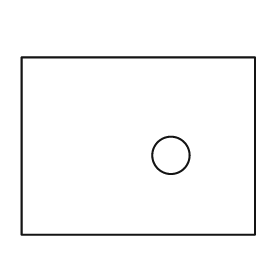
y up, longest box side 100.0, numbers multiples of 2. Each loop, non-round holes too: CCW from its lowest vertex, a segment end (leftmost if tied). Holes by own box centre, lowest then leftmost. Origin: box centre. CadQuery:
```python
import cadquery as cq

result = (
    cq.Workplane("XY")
    .moveTo(-50.0, -38.0)
    .lineTo(50.0, -38.0)
    .lineTo(50.0, 38.0)
    .lineTo(-50.0, 38.0)
    .close()
    .moveTo(14.0, -4.0)
    .circle(8.0)
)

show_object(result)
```